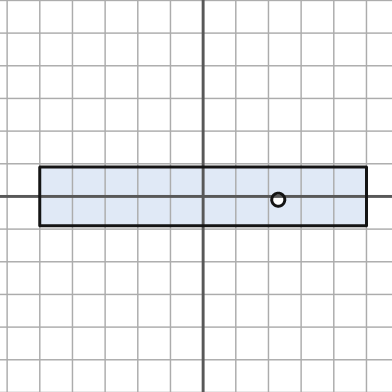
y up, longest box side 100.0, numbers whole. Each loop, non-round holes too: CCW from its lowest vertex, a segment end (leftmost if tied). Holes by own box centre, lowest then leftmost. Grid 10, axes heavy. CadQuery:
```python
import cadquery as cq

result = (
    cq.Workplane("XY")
    .moveTo(-50.0, -9.0)
    .lineTo(50.0, -9.0)
    .lineTo(50.0, 9.0)
    .lineTo(-50.0, 9.0)
    .close()
    .moveTo(23.0, -1.0)
    .circle(2.0)
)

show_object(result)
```